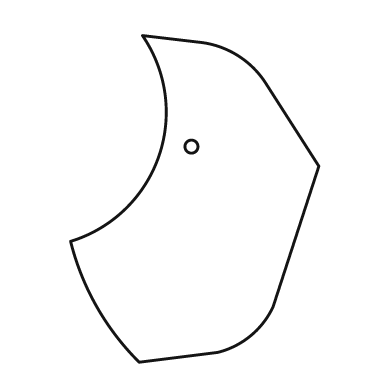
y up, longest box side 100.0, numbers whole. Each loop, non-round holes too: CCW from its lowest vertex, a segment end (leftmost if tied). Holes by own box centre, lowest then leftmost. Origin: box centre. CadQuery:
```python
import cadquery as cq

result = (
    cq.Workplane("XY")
    .moveTo(-17.0, -50.0)
    .lineTo(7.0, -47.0)
    .threePointArc((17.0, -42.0), (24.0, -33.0))
    .lineTo(38.0, 10.0)
    .lineTo(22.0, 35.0)
    .threePointArc((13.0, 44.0), (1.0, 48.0))
    .lineTo(-16.0, 50.0)
    .threePointArc((-11.0, 13.0), (-38.0, -13.0))
    .threePointArc((-30.0, -33.0), (-17.0, -50.0))
    .close()
    .moveTo(-1.0, 16.0)
    .circle(2.0)
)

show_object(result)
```